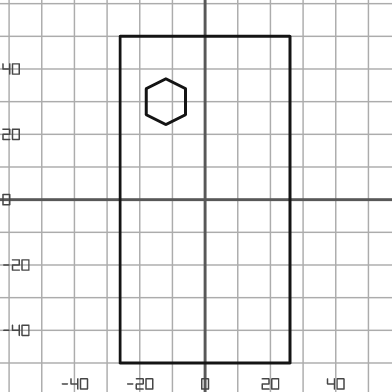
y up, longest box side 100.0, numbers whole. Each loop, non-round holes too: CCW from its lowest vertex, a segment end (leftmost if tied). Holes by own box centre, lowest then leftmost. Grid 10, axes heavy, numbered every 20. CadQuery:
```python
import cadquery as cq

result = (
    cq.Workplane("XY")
    .moveTo(-26.0, -50.0)
    .lineTo(26.0, -50.0)
    .lineTo(26.0, 50.0)
    .lineTo(-26.0, 50.0)
    .close()
    .moveTo(-12.0, 23.0)
    .lineTo(-6.0, 26.0)
    .lineTo(-6.0, 34.0)
    .lineTo(-12.0, 37.0)
    .lineTo(-18.0, 34.0)
    .lineTo(-18.0, 26.0)
    .close()
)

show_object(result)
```